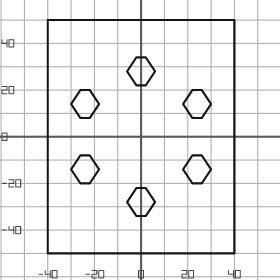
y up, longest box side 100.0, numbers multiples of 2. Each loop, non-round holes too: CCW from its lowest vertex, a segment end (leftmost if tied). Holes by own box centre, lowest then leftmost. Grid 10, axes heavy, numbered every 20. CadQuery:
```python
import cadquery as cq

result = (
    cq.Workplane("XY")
    .moveTo(-40.0, -50.0)
    .lineTo(40.0, -50.0)
    .lineTo(40.0, 50.0)
    .lineTo(-40.0, 50.0)
    .close()
    .moveTo(-2.0, -34.0)
    .lineTo(2.0, -34.0)
    .lineTo(6.0, -28.0)
    .lineTo(2.0, -22.0)
    .lineTo(-2.0, -22.0)
    .lineTo(-6.0, -28.0)
    .close()
    .moveTo(-26.0, -20.0)
    .lineTo(-22.0, -20.0)
    .lineTo(-18.0, -14.0)
    .lineTo(-22.0, -8.0)
    .lineTo(-26.0, -8.0)
    .lineTo(-30.0, -14.0)
    .close()
    .moveTo(22.0, -20.0)
    .lineTo(26.0, -20.0)
    .lineTo(30.0, -14.0)
    .lineTo(26.0, -8.0)
    .lineTo(22.0, -8.0)
    .lineTo(18.0, -14.0)
    .close()
    .moveTo(-26.0, 8.0)
    .lineTo(-22.0, 8.0)
    .lineTo(-18.0, 14.0)
    .lineTo(-22.0, 20.0)
    .lineTo(-26.0, 20.0)
    .lineTo(-30.0, 14.0)
    .close()
    .moveTo(22.0, 8.0)
    .lineTo(26.0, 8.0)
    .lineTo(30.0, 14.0)
    .lineTo(26.0, 20.0)
    .lineTo(22.0, 20.0)
    .lineTo(18.0, 14.0)
    .close()
    .moveTo(-2.0, 22.0)
    .lineTo(2.0, 22.0)
    .lineTo(6.0, 28.0)
    .lineTo(2.0, 34.0)
    .lineTo(-2.0, 34.0)
    .lineTo(-6.0, 28.0)
    .close()
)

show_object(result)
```